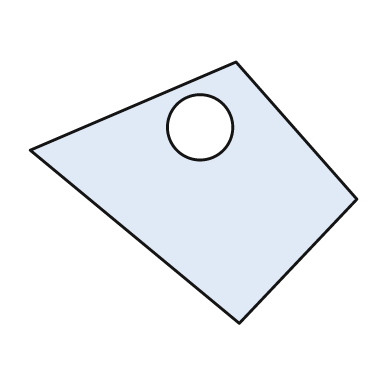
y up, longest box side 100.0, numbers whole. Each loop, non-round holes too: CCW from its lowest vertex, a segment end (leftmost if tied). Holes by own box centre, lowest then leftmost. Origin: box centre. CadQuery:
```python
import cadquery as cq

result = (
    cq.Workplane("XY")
    .moveTo(14.0, -40.0)
    .lineTo(50.0, -2.0)
    .lineTo(13.0, 40.0)
    .lineTo(-50.0, 13.0)
    .close()
    .moveTo(2.0, 20.0)
    .circle(10.0)
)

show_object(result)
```